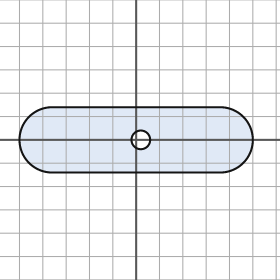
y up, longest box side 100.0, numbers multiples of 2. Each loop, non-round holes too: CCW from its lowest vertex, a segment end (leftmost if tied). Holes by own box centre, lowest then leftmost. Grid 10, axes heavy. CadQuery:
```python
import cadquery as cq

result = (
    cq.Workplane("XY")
    .moveTo(-36.0, -14.0)
    .lineTo(36.0, -14.0)
    .threePointArc((50.0, 0.0), (36.0, 14.0))
    .lineTo(-36.0, 14.0)
    .threePointArc((-50.0, 0.0), (-36.0, -14.0))
    .close()
    .moveTo(2.0, 0.0)
    .circle(4.0)
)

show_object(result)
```